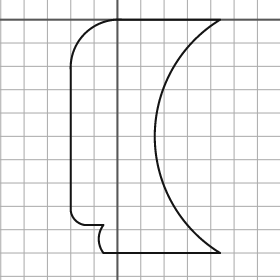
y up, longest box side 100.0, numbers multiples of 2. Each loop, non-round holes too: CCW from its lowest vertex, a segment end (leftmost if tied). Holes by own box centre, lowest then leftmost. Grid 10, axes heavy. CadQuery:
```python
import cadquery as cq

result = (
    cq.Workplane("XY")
    .moveTo(-6.0, -100.0)
    .lineTo(44.0, -100.0)
    .threePointArc((16.0, -50.0), (44.0, 0.0))
    .lineTo(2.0, 0.0)
    .threePointArc((-14.0, -6.0), (-20.0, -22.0))
    .lineTo(-20.0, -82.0)
    .threePointArc((-18.0, -86.0), (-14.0, -88.0))
    .lineTo(-6.0, -88.0)
    .threePointArc((-8.0, -94.0), (-6.0, -100.0))
    .close()
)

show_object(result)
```